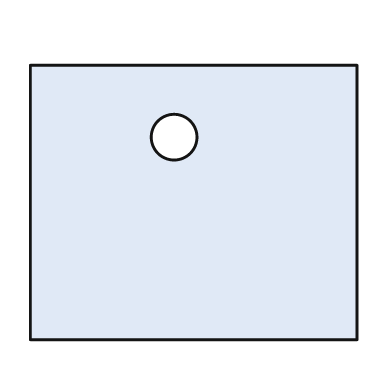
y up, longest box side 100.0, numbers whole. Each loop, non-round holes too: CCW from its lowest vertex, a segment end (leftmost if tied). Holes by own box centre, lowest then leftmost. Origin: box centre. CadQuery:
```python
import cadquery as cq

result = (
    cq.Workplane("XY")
    .moveTo(-50.0, -42.0)
    .lineTo(50.0, -42.0)
    .lineTo(50.0, 42.0)
    .lineTo(-50.0, 42.0)
    .close()
    .moveTo(-6.0, 20.0)
    .circle(7.0)
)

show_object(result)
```